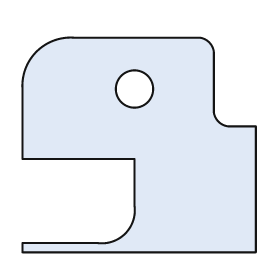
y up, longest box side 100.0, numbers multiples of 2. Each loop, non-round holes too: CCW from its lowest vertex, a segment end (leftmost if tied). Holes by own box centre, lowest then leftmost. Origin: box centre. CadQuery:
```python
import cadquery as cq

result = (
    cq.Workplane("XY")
    .moveTo(-50.0, -46.0)
    .lineTo(50.0, -46.0)
    .lineTo(50.0, 8.0)
    .lineTo(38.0, 8.0)
    .threePointArc((34.0, 10.0), (32.0, 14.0))
    .lineTo(32.0, 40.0)
    .threePointArc((30.0, 44.0), (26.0, 46.0))
    .lineTo(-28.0, 46.0)
    .threePointArc((-44.0, 40.0), (-50.0, 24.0))
    .lineTo(-50.0, -6.0)
    .lineTo(-2.0, -6.0)
    .lineTo(-2.0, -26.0)
    .threePointArc((-6.0, -38.0), (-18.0, -42.0))
    .lineTo(-50.0, -42.0)
    .close()
    .moveTo(-2.0, 24.0)
    .circle(8.0)
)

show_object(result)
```